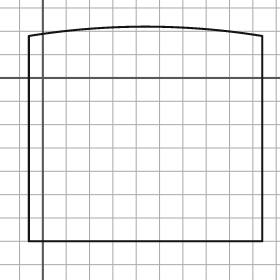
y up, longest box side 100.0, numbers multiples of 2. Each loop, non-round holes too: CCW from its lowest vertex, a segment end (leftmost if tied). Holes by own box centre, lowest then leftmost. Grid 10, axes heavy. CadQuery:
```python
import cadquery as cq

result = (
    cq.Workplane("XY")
    .moveTo(-6.0, -70.0)
    .lineTo(94.0, -70.0)
    .lineTo(94.0, 18.0)
    .threePointArc((44.0, 22.0), (-6.0, 18.0))
    .close()
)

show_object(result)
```